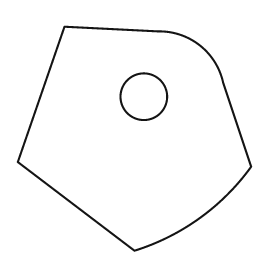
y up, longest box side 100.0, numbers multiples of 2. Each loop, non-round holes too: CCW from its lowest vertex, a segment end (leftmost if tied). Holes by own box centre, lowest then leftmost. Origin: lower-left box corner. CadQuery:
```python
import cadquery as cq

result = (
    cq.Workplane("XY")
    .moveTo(50.0, 0.0)
    .threePointArc((78.0, 14.0), (100.0, 36.0))
    .lineTo(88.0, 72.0)
    .threePointArc((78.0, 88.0), (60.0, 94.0))
    .lineTo(20.0, 96.0)
    .lineTo(0.0, 38.0)
    .close()
    .moveTo(54.0, 66.0)
    .circle(10.0)
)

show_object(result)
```